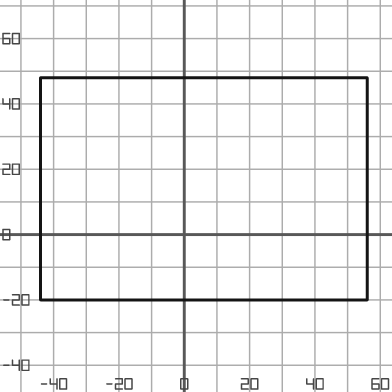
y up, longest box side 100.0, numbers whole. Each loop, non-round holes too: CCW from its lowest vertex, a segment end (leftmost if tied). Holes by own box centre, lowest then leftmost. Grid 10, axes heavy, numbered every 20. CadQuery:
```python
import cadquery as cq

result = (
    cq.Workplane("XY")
    .moveTo(-44.0, -20.0)
    .lineTo(56.0, -20.0)
    .lineTo(56.0, 48.0)
    .lineTo(-44.0, 48.0)
    .close()
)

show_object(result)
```